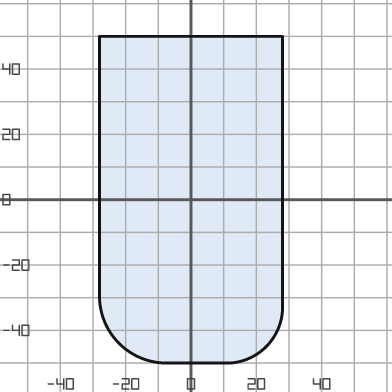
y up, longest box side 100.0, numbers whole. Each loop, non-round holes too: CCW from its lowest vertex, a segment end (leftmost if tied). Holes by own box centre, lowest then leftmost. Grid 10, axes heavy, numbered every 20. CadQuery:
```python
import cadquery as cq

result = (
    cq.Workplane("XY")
    .moveTo(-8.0, -50.0)
    .lineTo(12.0, -50.0)
    .threePointArc((23.0, -45.0), (28.0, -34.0))
    .lineTo(28.0, 50.0)
    .lineTo(-28.0, 50.0)
    .lineTo(-28.0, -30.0)
    .threePointArc((-22.0, -44.0), (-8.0, -50.0))
    .close()
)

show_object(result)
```